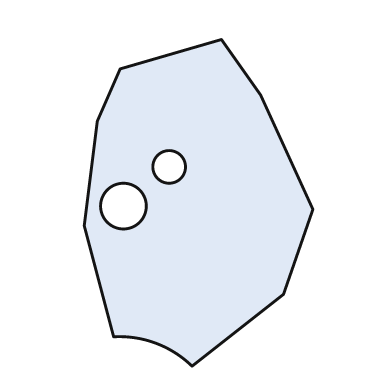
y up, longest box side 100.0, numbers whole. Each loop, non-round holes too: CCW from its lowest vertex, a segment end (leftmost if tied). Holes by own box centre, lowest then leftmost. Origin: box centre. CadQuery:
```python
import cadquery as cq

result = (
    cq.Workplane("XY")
    .moveTo(-2.0, -50.0)
    .lineTo(26.0, -28.0)
    .lineTo(35.0, -2.0)
    .lineTo(19.0, 33.0)
    .lineTo(7.0, 50.0)
    .lineTo(-24.0, 41.0)
    .lineTo(-31.0, 25.0)
    .lineTo(-35.0, -7.0)
    .lineTo(-26.0, -41.0)
    .threePointArc((-13.0, -43.0), (-2.0, -50.0))
    .close()
    .moveTo(-23.0, -1.0)
    .circle(7.0)
    .moveTo(-9.0, 11.0)
    .circle(5.0)
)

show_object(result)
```